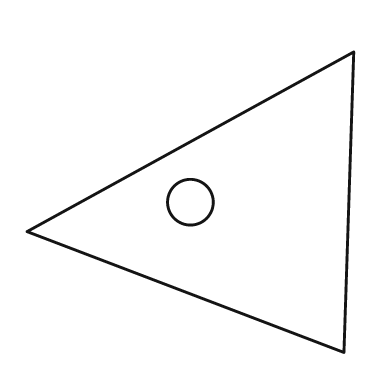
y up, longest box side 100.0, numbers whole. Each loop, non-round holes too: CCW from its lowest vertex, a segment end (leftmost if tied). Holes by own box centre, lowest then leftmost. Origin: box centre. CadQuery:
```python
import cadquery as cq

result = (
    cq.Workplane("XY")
    .moveTo(47.0, -46.0)
    .lineTo(50.0, 46.0)
    .lineTo(-50.0, -9.0)
    .close()
    .moveTo(0.0, 0.0)
    .circle(7.0)
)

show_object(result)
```